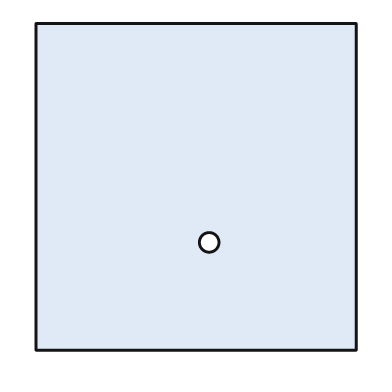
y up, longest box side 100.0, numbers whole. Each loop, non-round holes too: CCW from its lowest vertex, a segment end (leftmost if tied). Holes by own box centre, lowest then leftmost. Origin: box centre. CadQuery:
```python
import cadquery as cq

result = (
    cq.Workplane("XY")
    .moveTo(-49.0, -50.0)
    .lineTo(49.0, -50.0)
    .lineTo(49.0, 50.0)
    .lineTo(-49.0, 50.0)
    .close()
    .moveTo(4.0, -17.0)
    .circle(3.0)
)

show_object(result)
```